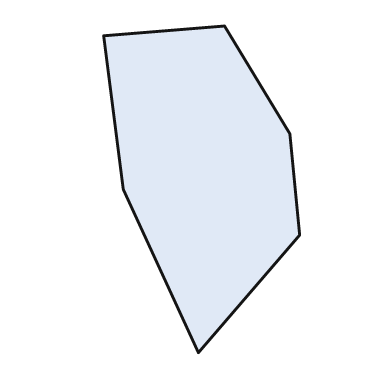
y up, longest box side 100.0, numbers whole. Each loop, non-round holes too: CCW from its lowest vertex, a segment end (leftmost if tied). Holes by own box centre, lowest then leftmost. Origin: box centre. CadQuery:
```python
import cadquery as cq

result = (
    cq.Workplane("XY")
    .moveTo(-1.0, -50.0)
    .lineTo(30.0, -14.0)
    .lineTo(27.0, 17.0)
    .lineTo(7.0, 50.0)
    .lineTo(-30.0, 47.0)
    .lineTo(-24.0, 0.0)
    .close()
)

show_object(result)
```